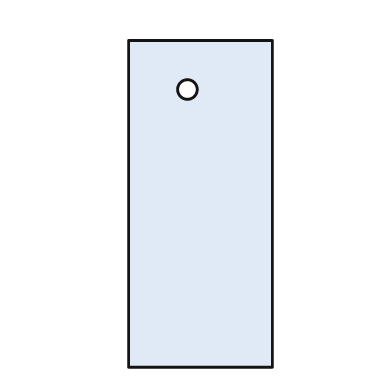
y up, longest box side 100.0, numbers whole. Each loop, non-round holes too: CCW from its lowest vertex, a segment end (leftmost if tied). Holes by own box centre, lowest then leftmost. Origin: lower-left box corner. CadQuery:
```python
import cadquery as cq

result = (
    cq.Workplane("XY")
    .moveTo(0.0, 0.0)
    .lineTo(44.0, 0.0)
    .lineTo(44.0, 100.0)
    .lineTo(0.0, 100.0)
    .close()
    .moveTo(18.0, 85.0)
    .circle(3.0)
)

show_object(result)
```